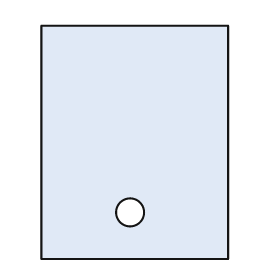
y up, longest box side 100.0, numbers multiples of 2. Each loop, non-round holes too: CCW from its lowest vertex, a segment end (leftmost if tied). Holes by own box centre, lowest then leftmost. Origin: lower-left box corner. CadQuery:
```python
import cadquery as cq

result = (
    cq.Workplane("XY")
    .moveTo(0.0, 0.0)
    .lineTo(80.0, 0.0)
    .lineTo(80.0, 100.0)
    .lineTo(0.0, 100.0)
    .close()
    .moveTo(38.0, 20.0)
    .circle(6.0)
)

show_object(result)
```